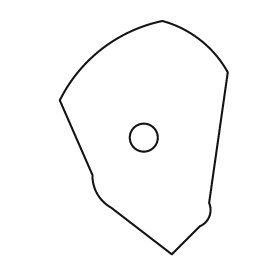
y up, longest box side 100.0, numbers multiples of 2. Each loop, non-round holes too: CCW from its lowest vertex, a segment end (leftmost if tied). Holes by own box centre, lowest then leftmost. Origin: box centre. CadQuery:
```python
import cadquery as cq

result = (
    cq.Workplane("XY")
    .moveTo(12.0, -50.0)
    .lineTo(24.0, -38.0)
    .threePointArc((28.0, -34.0), (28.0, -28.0))
    .lineTo(36.0, 28.0)
    .threePointArc((24.0, 42.0), (8.0, 50.0))
    .threePointArc((-18.0, 38.0), (-36.0, 16.0))
    .lineTo(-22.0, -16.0)
    .threePointArc((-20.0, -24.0), (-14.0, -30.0))
    .close()
    .moveTo(0.0, 0.0)
    .circle(6.0)
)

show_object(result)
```